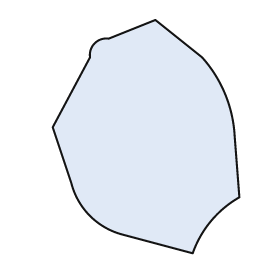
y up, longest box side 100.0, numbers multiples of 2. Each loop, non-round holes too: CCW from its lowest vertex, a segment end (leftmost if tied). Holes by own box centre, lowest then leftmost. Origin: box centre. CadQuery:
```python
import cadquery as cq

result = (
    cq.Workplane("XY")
    .moveTo(20.0, -50.0)
    .threePointArc((28.0, -36.0), (40.0, -26.0))
    .lineTo(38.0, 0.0)
    .threePointArc((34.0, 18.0), (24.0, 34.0))
    .lineTo(4.0, 50.0)
    .lineTo(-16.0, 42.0)
    .threePointArc((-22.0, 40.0), (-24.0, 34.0))
    .lineTo(-40.0, 4.0)
    .lineTo(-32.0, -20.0)
    .threePointArc((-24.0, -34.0), (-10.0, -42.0))
    .close()
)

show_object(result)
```